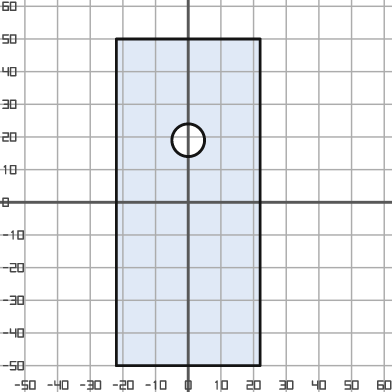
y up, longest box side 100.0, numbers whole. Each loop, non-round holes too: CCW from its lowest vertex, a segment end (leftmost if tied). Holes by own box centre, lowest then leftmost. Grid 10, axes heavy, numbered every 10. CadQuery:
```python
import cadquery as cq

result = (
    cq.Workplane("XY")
    .moveTo(-22.0, -50.0)
    .lineTo(22.0, -50.0)
    .lineTo(22.0, 50.0)
    .lineTo(-22.0, 50.0)
    .close()
    .moveTo(0.0, 19.0)
    .circle(5.0)
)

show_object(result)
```